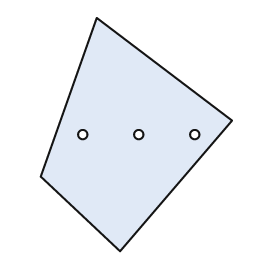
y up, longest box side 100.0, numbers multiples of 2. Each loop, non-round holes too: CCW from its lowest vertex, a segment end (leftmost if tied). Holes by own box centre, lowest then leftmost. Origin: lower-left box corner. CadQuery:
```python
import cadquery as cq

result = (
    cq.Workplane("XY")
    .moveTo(34.0, 0.0)
    .lineTo(82.0, 56.0)
    .lineTo(24.0, 100.0)
    .lineTo(0.0, 32.0)
    .close()
    .moveTo(18.0, 50.0)
    .circle(2.0)
    .moveTo(42.0, 50.0)
    .circle(2.0)
    .moveTo(66.0, 50.0)
    .circle(2.0)
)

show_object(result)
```